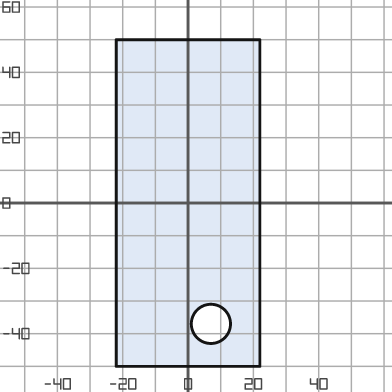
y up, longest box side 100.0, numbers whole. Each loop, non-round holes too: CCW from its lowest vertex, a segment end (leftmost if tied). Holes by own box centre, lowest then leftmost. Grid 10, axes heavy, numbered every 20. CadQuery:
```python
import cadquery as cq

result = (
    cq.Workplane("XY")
    .moveTo(-22.0, -50.0)
    .lineTo(22.0, -50.0)
    .lineTo(22.0, 50.0)
    .lineTo(-22.0, 50.0)
    .close()
    .moveTo(7.0, -37.0)
    .circle(6.0)
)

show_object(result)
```